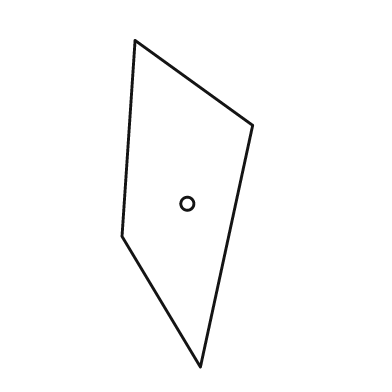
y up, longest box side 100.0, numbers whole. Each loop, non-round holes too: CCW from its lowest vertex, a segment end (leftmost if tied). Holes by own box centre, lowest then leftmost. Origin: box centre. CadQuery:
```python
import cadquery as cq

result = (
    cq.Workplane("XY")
    .moveTo(4.0, -50.0)
    .lineTo(20.0, 24.0)
    .lineTo(-16.0, 50.0)
    .lineTo(-20.0, -10.0)
    .close()
    .moveTo(0.0, 0.0)
    .circle(2.0)
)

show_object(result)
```